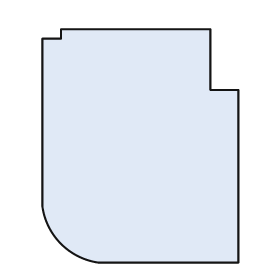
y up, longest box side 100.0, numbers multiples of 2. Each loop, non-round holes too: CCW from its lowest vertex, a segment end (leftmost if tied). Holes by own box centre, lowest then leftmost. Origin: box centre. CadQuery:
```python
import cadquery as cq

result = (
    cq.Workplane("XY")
    .moveTo(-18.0, -50.0)
    .lineTo(42.0, -50.0)
    .lineTo(42.0, 24.0)
    .lineTo(30.0, 24.0)
    .lineTo(30.0, 50.0)
    .lineTo(-34.0, 50.0)
    .lineTo(-34.0, 46.0)
    .lineTo(-42.0, 46.0)
    .lineTo(-42.0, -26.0)
    .threePointArc((-34.0, -42.0), (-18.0, -50.0))
    .close()
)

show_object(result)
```